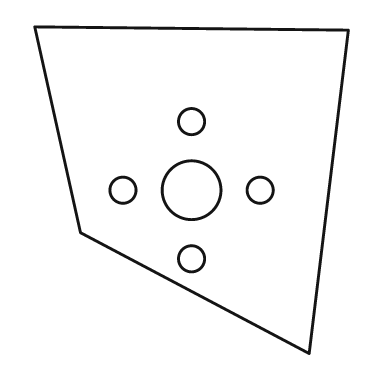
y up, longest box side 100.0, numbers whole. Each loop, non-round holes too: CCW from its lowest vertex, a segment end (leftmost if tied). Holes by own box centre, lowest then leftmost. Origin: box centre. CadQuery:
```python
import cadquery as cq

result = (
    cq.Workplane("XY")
    .moveTo(36.0, -50.0)
    .lineTo(48.0, 49.0)
    .lineTo(-48.0, 50.0)
    .lineTo(-34.0, -13.0)
    .close()
    .moveTo(0.0, -21.0)
    .circle(4.0)
    .moveTo(-21.0, 0.0)
    .circle(4.0)
    .moveTo(0.0, 0.0)
    .circle(9.0)
    .moveTo(21.0, 0.0)
    .circle(4.0)
    .moveTo(0.0, 21.0)
    .circle(4.0)
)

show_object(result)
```